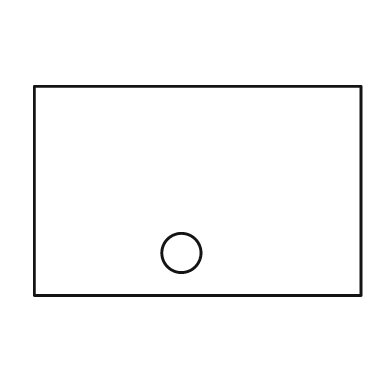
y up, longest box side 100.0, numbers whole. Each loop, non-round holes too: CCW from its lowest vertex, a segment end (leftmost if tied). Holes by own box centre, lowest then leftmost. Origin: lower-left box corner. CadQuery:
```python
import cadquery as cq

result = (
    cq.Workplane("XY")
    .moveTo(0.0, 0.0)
    .lineTo(100.0, 0.0)
    .lineTo(100.0, 64.0)
    .lineTo(0.0, 64.0)
    .close()
    .moveTo(45.0, 13.0)
    .circle(6.0)
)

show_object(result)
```